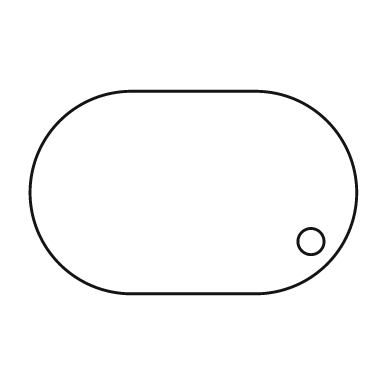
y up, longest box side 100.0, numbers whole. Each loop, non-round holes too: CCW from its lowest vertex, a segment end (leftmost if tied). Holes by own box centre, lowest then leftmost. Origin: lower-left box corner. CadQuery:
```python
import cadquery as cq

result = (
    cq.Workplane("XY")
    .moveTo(31.0, 0.0)
    .lineTo(69.0, 0.0)
    .threePointArc((100.0, 31.0), (69.0, 62.0))
    .lineTo(31.0, 62.0)
    .threePointArc((0.0, 31.0), (31.0, 0.0))
    .close()
    .moveTo(86.0, 16.0)
    .circle(4.0)
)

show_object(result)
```